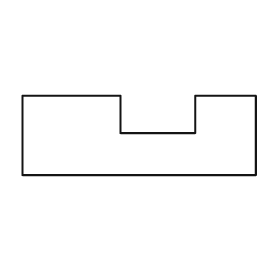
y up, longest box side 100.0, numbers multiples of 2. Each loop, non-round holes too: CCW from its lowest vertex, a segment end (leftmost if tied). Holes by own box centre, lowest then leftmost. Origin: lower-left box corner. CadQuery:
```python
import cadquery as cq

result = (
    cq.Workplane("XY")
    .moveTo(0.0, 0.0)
    .lineTo(100.0, 0.0)
    .lineTo(100.0, 34.0)
    .lineTo(74.0, 34.0)
    .lineTo(74.0, 18.0)
    .lineTo(42.0, 18.0)
    .lineTo(42.0, 34.0)
    .lineTo(0.0, 34.0)
    .close()
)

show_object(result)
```